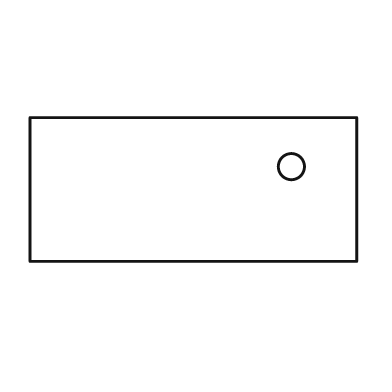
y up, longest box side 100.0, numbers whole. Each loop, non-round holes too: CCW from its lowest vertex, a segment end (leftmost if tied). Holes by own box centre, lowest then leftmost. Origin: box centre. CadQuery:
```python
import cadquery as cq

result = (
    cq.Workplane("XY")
    .moveTo(-50.0, -22.0)
    .lineTo(50.0, -22.0)
    .lineTo(50.0, 22.0)
    .lineTo(-50.0, 22.0)
    .close()
    .moveTo(30.0, 7.0)
    .circle(4.0)
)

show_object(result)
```